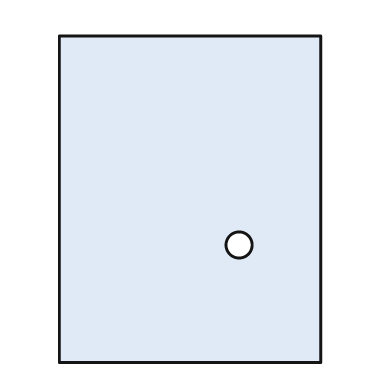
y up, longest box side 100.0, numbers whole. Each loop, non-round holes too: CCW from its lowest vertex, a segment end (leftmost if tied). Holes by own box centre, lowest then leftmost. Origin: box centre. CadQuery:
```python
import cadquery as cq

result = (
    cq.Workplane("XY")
    .moveTo(-40.0, -50.0)
    .lineTo(40.0, -50.0)
    .lineTo(40.0, 50.0)
    .lineTo(-40.0, 50.0)
    .close()
    .moveTo(15.0, -14.0)
    .circle(4.0)
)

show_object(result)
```